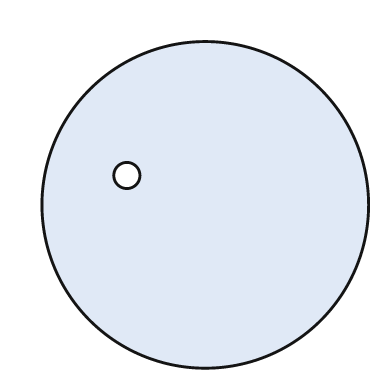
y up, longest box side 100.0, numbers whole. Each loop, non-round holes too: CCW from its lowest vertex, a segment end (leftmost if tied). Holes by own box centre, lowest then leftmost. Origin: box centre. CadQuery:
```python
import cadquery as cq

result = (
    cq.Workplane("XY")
    .moveTo(0.0, 0.0)
    .circle(50.0)
    .moveTo(-24.0, 9.0)
    .circle(4.0)
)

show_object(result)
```